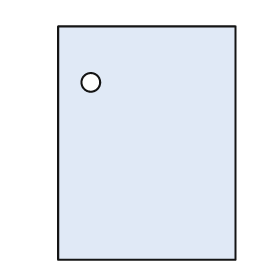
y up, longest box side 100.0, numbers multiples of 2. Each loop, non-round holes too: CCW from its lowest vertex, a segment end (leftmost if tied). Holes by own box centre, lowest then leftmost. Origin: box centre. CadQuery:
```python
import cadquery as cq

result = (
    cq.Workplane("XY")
    .moveTo(-38.0, -50.0)
    .lineTo(38.0, -50.0)
    .lineTo(38.0, 50.0)
    .lineTo(-38.0, 50.0)
    .close()
    .moveTo(-24.0, 26.0)
    .circle(4.0)
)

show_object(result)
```